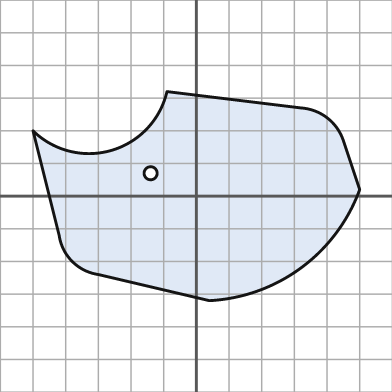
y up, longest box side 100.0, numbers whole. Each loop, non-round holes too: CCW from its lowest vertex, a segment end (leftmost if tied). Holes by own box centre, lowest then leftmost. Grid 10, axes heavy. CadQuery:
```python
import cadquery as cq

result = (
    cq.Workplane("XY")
    .moveTo(4.0, -32.0)
    .threePointArc((32.0, -22.0), (50.0, 2.0))
    .lineTo(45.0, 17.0)
    .threePointArc((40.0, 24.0), (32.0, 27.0))
    .lineTo(-9.0, 32.0)
    .threePointArc((-26.0, 14.0), (-50.0, 20.0))
    .lineTo(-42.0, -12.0)
    .threePointArc((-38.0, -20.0), (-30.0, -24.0))
    .close()
    .moveTo(-14.0, 7.0)
    .circle(2.0)
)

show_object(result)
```